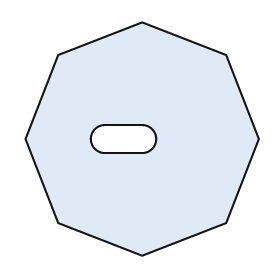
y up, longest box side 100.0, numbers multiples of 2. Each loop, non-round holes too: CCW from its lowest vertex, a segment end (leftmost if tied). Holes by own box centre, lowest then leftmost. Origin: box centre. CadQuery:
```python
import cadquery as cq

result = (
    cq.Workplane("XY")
    .moveTo(0.0, -50.0)
    .lineTo(36.0, -36.0)
    .lineTo(50.0, 0.0)
    .lineTo(36.0, 36.0)
    .lineTo(0.0, 50.0)
    .lineTo(-36.0, 36.0)
    .lineTo(-50.0, 0.0)
    .lineTo(-36.0, -36.0)
    .close()
    .moveTo(-16.0, -6.0)
    .lineTo(0.0, -6.0)
    .threePointArc((6.0, 0.0), (0.0, 6.0))
    .lineTo(-16.0, 6.0)
    .threePointArc((-22.0, 0.0), (-16.0, -6.0))
    .close()
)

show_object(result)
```